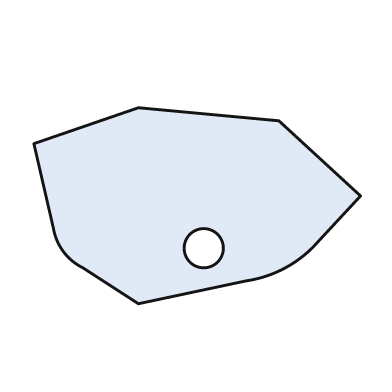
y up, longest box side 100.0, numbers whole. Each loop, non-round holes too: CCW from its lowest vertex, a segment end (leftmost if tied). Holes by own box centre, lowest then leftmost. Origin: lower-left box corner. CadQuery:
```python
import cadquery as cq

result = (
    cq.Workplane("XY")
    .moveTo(32.0, 0.0)
    .lineTo(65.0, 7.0)
    .threePointArc((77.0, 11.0), (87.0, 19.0))
    .lineTo(100.0, 33.0)
    .lineTo(75.0, 56.0)
    .lineTo(32.0, 60.0)
    .lineTo(0.0, 49.0)
    .lineTo(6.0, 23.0)
    .threePointArc((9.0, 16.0), (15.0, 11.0))
    .close()
    .moveTo(52.0, 17.0)
    .circle(6.0)
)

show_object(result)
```